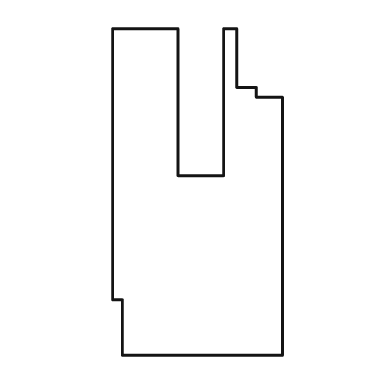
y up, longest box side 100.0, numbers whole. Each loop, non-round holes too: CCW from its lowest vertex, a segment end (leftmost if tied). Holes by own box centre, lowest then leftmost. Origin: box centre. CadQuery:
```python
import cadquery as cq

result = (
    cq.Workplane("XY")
    .moveTo(-23.0, -50.0)
    .lineTo(26.0, -50.0)
    .lineTo(26.0, 29.0)
    .lineTo(18.0, 29.0)
    .lineTo(18.0, 32.0)
    .lineTo(12.0, 32.0)
    .lineTo(12.0, 50.0)
    .lineTo(8.0, 50.0)
    .lineTo(8.0, 5.0)
    .lineTo(-6.0, 5.0)
    .lineTo(-6.0, 50.0)
    .lineTo(-26.0, 50.0)
    .lineTo(-26.0, -33.0)
    .lineTo(-23.0, -33.0)
    .close()
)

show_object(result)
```